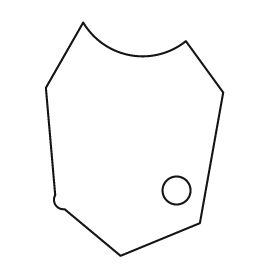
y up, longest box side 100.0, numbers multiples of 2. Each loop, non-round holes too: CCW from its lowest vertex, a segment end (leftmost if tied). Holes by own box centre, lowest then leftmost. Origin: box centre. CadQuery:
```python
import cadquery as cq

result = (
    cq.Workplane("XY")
    .moveTo(-6.0, -50.0)
    .lineTo(28.0, -36.0)
    .lineTo(38.0, 20.0)
    .lineTo(22.0, 42.0)
    .threePointArc((-2.0, 36.0), (-22.0, 50.0))
    .lineTo(-38.0, 22.0)
    .lineTo(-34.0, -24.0)
    .threePointArc((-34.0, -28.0), (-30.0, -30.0))
    .close()
    .moveTo(18.0, -22.0)
    .circle(6.0)
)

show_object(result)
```